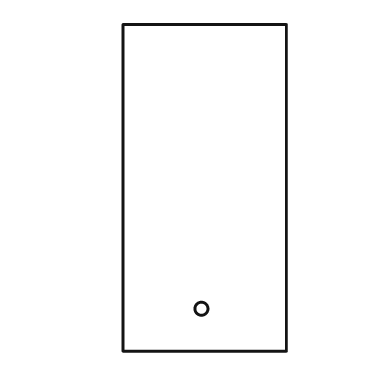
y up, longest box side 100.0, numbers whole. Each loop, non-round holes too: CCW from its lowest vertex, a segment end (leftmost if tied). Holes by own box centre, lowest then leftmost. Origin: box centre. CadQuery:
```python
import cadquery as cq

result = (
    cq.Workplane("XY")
    .moveTo(-25.0, -50.0)
    .lineTo(25.0, -50.0)
    .lineTo(25.0, 50.0)
    .lineTo(-25.0, 50.0)
    .close()
    .moveTo(-1.0, -37.0)
    .circle(2.0)
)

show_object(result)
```